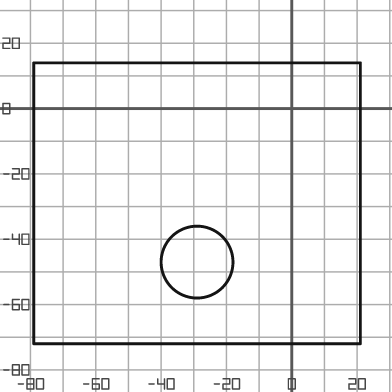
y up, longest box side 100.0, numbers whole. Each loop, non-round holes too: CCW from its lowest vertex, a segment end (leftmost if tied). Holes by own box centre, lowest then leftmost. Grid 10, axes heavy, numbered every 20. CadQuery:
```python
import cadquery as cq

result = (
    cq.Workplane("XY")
    .moveTo(-79.0, -72.0)
    .lineTo(21.0, -72.0)
    .lineTo(21.0, 14.0)
    .lineTo(-79.0, 14.0)
    .close()
    .moveTo(-29.0, -47.0)
    .circle(11.0)
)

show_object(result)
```